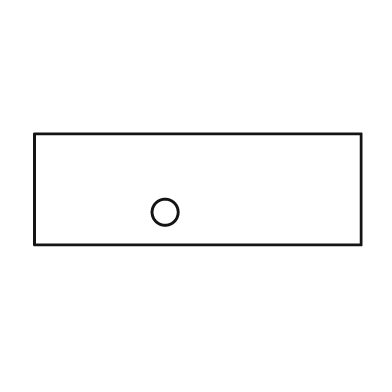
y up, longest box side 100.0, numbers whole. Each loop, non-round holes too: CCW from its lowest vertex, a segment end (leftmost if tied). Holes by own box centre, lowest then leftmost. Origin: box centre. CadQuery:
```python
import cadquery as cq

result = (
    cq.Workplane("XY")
    .moveTo(-50.0, -17.0)
    .lineTo(50.0, -17.0)
    .lineTo(50.0, 17.0)
    .lineTo(-50.0, 17.0)
    .close()
    .moveTo(-10.0, -7.0)
    .circle(4.0)
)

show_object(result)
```